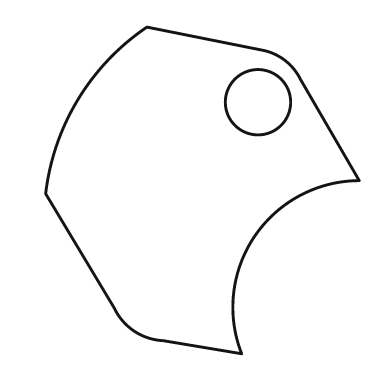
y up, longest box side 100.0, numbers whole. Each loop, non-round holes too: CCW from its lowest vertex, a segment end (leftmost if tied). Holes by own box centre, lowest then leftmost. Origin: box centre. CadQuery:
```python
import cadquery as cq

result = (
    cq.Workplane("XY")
    .moveTo(12.0, -50.0)
    .threePointArc((16.0, -14.0), (48.0, 3.0))
    .lineTo(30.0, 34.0)
    .threePointArc((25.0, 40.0), (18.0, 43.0))
    .lineTo(-17.0, 50.0)
    .threePointArc((-38.0, 28.0), (-48.0, -1.0))
    .lineTo(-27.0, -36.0)
    .threePointArc((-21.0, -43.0), (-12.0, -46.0))
    .close()
    .moveTo(17.0, 27.0)
    .circle(10.0)
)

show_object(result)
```